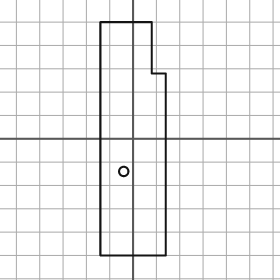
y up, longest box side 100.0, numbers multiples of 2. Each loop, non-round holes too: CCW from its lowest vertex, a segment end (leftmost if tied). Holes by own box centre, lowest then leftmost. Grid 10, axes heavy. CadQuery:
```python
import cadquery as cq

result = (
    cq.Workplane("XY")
    .moveTo(-14.0, -50.0)
    .lineTo(14.0, -50.0)
    .lineTo(14.0, 28.0)
    .lineTo(8.0, 28.0)
    .lineTo(8.0, 50.0)
    .lineTo(-14.0, 50.0)
    .close()
    .moveTo(-4.0, -14.0)
    .circle(2.0)
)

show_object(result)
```